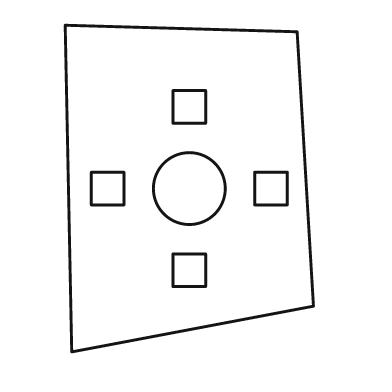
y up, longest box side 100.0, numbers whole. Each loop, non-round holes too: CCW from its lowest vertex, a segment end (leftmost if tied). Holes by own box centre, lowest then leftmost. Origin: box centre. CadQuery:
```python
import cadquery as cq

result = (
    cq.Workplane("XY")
    .moveTo(-36.0, -50.0)
    .lineTo(38.0, -36.0)
    .lineTo(33.0, 48.0)
    .lineTo(-38.0, 50.0)
    .close()
    .moveTo(-5.0, -30.0)
    .lineTo(5.0, -30.0)
    .lineTo(5.0, -20.0)
    .lineTo(-5.0, -20.0)
    .close()
    .moveTo(-30.0, -5.0)
    .lineTo(-20.0, -5.0)
    .lineTo(-20.0, 5.0)
    .lineTo(-30.0, 5.0)
    .close()
    .moveTo(0.0, 0.0)
    .circle(11.0)
    .moveTo(20.0, -5.0)
    .lineTo(30.0, -5.0)
    .lineTo(30.0, 5.0)
    .lineTo(20.0, 5.0)
    .close()
    .moveTo(-5.0, 20.0)
    .lineTo(5.0, 20.0)
    .lineTo(5.0, 30.0)
    .lineTo(-5.0, 30.0)
    .close()
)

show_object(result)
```